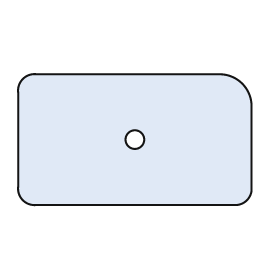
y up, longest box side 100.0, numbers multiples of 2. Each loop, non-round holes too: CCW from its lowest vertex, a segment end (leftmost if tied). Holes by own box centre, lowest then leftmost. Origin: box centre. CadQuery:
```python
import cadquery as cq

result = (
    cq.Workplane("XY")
    .moveTo(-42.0, -28.0)
    .lineTo(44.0, -28.0)
    .threePointArc((48.0, -26.0), (50.0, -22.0))
    .lineTo(50.0, 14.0)
    .threePointArc((46.0, 24.0), (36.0, 28.0))
    .lineTo(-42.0, 28.0)
    .threePointArc((-48.0, 26.0), (-50.0, 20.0))
    .lineTo(-50.0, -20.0)
    .threePointArc((-48.0, -26.0), (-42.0, -28.0))
    .close()
    .moveTo(0.0, 0.0)
    .circle(4.0)
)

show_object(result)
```